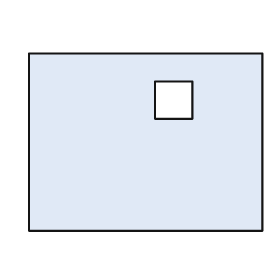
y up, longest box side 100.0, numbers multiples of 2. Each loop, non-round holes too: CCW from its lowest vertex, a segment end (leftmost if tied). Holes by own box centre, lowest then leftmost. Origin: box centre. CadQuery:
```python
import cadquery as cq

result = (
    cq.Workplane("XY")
    .moveTo(-50.0, -38.0)
    .lineTo(50.0, -38.0)
    .lineTo(50.0, 38.0)
    .lineTo(-50.0, 38.0)
    .close()
    .moveTo(4.0, 10.0)
    .lineTo(20.0, 10.0)
    .lineTo(20.0, 26.0)
    .lineTo(4.0, 26.0)
    .close()
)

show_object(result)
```